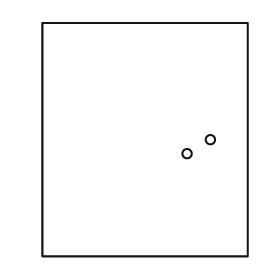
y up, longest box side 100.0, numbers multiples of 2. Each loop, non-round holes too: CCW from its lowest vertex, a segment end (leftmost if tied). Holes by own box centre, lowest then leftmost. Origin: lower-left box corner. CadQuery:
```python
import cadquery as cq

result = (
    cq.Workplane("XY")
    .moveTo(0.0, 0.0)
    .lineTo(88.0, 0.0)
    .lineTo(88.0, 100.0)
    .lineTo(0.0, 100.0)
    .close()
    .moveTo(62.0, 44.0)
    .circle(2.0)
    .moveTo(72.0, 50.0)
    .circle(2.0)
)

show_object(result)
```